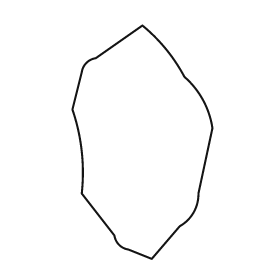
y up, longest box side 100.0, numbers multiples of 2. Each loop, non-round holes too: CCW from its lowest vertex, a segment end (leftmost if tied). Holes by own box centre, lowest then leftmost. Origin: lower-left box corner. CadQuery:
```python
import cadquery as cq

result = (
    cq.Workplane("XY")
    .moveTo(34.0, 0.0)
    .lineTo(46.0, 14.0)
    .threePointArc((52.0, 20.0), (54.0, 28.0))
    .lineTo(60.0, 56.0)
    .threePointArc((56.0, 68.0), (48.0, 78.0))
    .threePointArc((40.0, 90.0), (30.0, 100.0))
    .lineTo(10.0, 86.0)
    .threePointArc((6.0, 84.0), (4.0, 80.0))
    .lineTo(0.0, 64.0)
    .threePointArc((4.0, 46.0), (4.0, 28.0))
    .lineTo(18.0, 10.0)
    .threePointArc((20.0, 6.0), (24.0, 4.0))
    .close()
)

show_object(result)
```